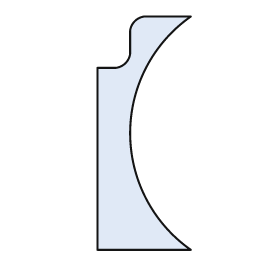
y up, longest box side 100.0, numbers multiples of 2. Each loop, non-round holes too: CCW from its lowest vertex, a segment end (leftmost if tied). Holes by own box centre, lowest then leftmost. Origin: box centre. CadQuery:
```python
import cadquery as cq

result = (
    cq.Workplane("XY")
    .moveTo(-20.0, -50.0)
    .lineTo(20.0, -50.0)
    .threePointArc((-6.0, 0.0), (20.0, 50.0))
    .lineTo(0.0, 50.0)
    .threePointArc((-4.0, 48.0), (-6.0, 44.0))
    .lineTo(-6.0, 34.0)
    .threePointArc((-8.0, 30.0), (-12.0, 28.0))
    .lineTo(-20.0, 28.0)
    .close()
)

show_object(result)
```